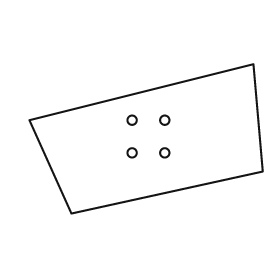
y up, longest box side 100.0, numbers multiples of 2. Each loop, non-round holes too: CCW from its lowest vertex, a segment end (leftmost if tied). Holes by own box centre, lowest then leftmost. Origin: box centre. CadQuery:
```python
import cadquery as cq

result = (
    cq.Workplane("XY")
    .moveTo(-32.0, -32.0)
    .lineTo(50.0, -14.0)
    .lineTo(46.0, 32.0)
    .lineTo(-50.0, 8.0)
    .close()
    .moveTo(-6.0, -6.0)
    .circle(2.0)
    .moveTo(8.0, -6.0)
    .circle(2.0)
    .moveTo(-6.0, 8.0)
    .circle(2.0)
    .moveTo(8.0, 8.0)
    .circle(2.0)
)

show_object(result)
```